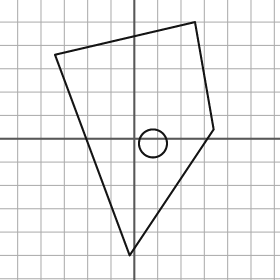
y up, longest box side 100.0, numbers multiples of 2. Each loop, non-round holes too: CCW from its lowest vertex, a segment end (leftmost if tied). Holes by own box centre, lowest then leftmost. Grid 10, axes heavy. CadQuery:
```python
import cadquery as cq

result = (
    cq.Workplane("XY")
    .moveTo(-2.0, -50.0)
    .lineTo(34.0, 4.0)
    .lineTo(26.0, 50.0)
    .lineTo(-34.0, 36.0)
    .close()
    .moveTo(8.0, -2.0)
    .circle(6.0)
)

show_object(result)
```